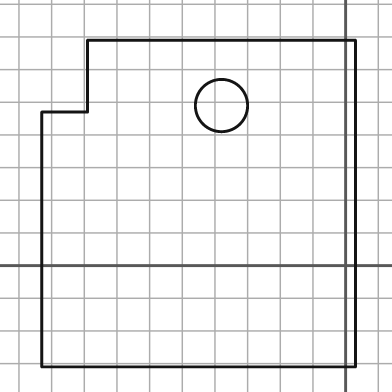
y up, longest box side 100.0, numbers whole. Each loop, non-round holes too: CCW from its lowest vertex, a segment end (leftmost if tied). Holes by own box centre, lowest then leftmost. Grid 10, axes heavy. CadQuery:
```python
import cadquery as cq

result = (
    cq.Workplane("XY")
    .moveTo(-93.0, -31.0)
    .lineTo(3.0, -31.0)
    .lineTo(3.0, 69.0)
    .lineTo(-79.0, 69.0)
    .lineTo(-79.0, 47.0)
    .lineTo(-93.0, 47.0)
    .close()
    .moveTo(-38.0, 49.0)
    .circle(8.0)
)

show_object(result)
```